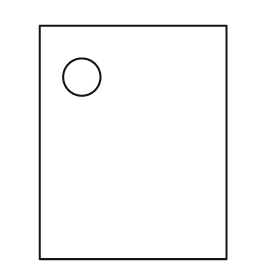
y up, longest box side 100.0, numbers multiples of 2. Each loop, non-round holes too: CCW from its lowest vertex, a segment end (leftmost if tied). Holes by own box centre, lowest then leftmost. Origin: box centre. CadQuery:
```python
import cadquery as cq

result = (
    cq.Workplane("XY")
    .moveTo(-40.0, -50.0)
    .lineTo(40.0, -50.0)
    .lineTo(40.0, 50.0)
    .lineTo(-40.0, 50.0)
    .close()
    .moveTo(-22.0, 28.0)
    .circle(8.0)
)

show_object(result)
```